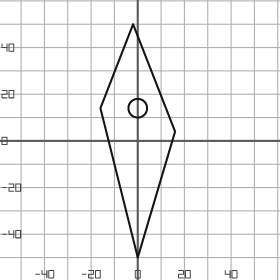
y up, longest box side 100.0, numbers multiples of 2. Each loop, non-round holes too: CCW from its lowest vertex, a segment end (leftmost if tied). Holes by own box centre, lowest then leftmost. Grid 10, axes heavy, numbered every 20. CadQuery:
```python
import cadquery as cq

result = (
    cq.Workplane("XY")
    .moveTo(0.0, -50.0)
    .lineTo(16.0, 4.0)
    .lineTo(-2.0, 50.0)
    .lineTo(-16.0, 14.0)
    .close()
    .moveTo(0.0, 14.0)
    .circle(4.0)
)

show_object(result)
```